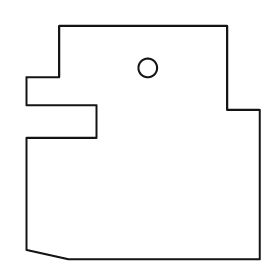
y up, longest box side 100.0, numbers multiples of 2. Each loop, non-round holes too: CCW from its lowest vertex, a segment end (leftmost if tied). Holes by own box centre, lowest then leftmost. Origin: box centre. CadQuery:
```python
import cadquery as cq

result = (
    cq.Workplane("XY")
    .moveTo(-32.0, -50.0)
    .lineTo(50.0, -50.0)
    .lineTo(50.0, 14.0)
    .lineTo(36.0, 14.0)
    .lineTo(36.0, 50.0)
    .lineTo(-36.0, 50.0)
    .lineTo(-36.0, 28.0)
    .lineTo(-50.0, 28.0)
    .lineTo(-50.0, 16.0)
    .lineTo(-20.0, 16.0)
    .lineTo(-20.0, 2.0)
    .lineTo(-50.0, 2.0)
    .lineTo(-50.0, -46.0)
    .close()
    .moveTo(2.0, 32.0)
    .circle(4.0)
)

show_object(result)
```